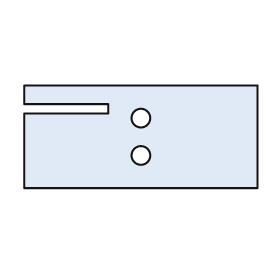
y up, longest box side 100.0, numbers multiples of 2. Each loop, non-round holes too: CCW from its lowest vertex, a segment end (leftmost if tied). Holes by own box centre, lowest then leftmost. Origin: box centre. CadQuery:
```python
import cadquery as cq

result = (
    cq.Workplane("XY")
    .moveTo(-50.0, -22.0)
    .lineTo(50.0, -22.0)
    .lineTo(50.0, 22.0)
    .lineTo(-50.0, 22.0)
    .lineTo(-50.0, 14.0)
    .lineTo(-14.0, 14.0)
    .lineTo(-14.0, 10.0)
    .lineTo(-50.0, 10.0)
    .close()
    .moveTo(0.0, -8.0)
    .circle(4.0)
    .moveTo(0.0, 8.0)
    .circle(4.0)
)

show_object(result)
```